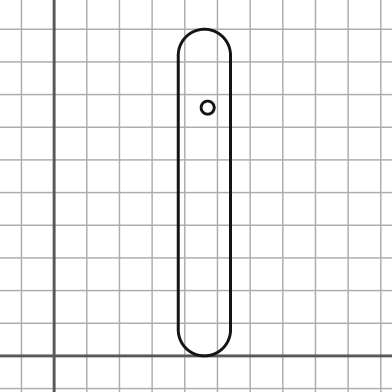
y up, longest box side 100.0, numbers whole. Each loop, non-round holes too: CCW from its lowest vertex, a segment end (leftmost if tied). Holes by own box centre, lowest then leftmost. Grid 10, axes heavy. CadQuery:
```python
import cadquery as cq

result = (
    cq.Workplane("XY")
    .moveTo(38.0, 8.0)
    .threePointArc((46.0, 0.0), (54.0, 8.0))
    .lineTo(54.0, 92.0)
    .threePointArc((46.0, 100.0), (38.0, 92.0))
    .close()
    .moveTo(47.0, 76.0)
    .circle(2.0)
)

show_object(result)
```